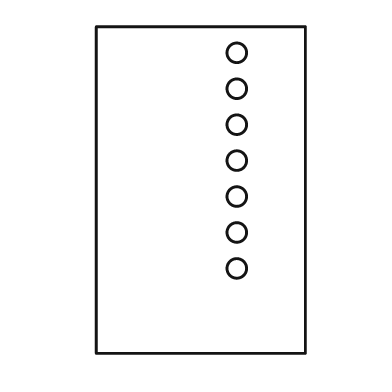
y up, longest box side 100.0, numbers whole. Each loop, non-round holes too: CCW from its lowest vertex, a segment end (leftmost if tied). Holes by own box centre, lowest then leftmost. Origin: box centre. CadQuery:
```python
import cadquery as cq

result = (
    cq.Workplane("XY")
    .moveTo(-32.0, -50.0)
    .lineTo(32.0, -50.0)
    .lineTo(32.0, 50.0)
    .lineTo(-32.0, 50.0)
    .close()
    .moveTo(11.0, -24.0)
    .circle(3.0)
    .moveTo(11.0, -13.0)
    .circle(3.0)
    .moveTo(11.0, -2.0)
    .circle(3.0)
    .moveTo(11.0, 9.0)
    .circle(3.0)
    .moveTo(11.0, 20.0)
    .circle(3.0)
    .moveTo(11.0, 31.0)
    .circle(3.0)
    .moveTo(11.0, 42.0)
    .circle(3.0)
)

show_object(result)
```